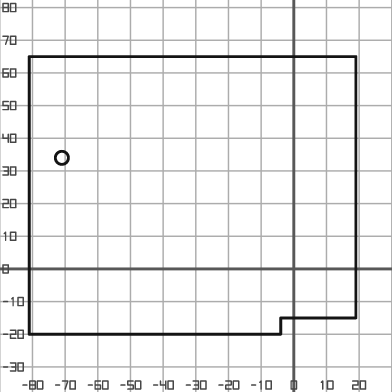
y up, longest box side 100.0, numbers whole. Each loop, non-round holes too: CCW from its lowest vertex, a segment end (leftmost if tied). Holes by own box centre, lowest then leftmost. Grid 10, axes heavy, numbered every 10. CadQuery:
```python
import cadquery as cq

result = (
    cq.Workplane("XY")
    .moveTo(-81.0, -20.0)
    .lineTo(-4.0, -20.0)
    .lineTo(-4.0, -15.0)
    .lineTo(19.0, -15.0)
    .lineTo(19.0, 65.0)
    .lineTo(-81.0, 65.0)
    .close()
    .moveTo(-71.0, 34.0)
    .circle(2.0)
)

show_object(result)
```